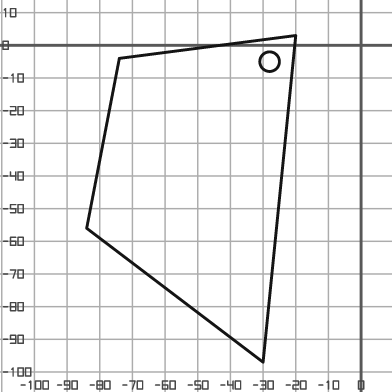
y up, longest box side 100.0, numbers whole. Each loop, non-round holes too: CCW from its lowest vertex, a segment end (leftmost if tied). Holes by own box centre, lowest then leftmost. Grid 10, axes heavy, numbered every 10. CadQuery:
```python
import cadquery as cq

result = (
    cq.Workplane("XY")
    .moveTo(-30.0, -97.0)
    .lineTo(-20.0, 3.0)
    .lineTo(-74.0, -4.0)
    .lineTo(-84.0, -56.0)
    .close()
    .moveTo(-28.0, -5.0)
    .circle(3.0)
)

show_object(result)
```